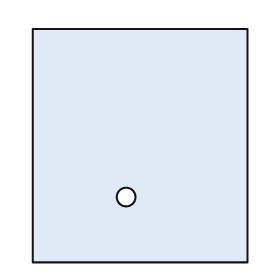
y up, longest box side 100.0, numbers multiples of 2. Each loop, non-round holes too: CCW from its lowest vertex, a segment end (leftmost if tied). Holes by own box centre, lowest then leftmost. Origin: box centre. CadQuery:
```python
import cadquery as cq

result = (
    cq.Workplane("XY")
    .moveTo(-46.0, -50.0)
    .lineTo(46.0, -50.0)
    .lineTo(46.0, 50.0)
    .lineTo(-46.0, 50.0)
    .close()
    .moveTo(-6.0, -22.0)
    .circle(4.0)
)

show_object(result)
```